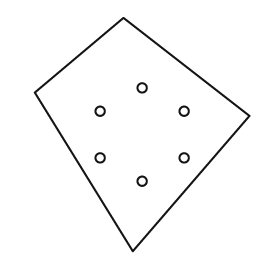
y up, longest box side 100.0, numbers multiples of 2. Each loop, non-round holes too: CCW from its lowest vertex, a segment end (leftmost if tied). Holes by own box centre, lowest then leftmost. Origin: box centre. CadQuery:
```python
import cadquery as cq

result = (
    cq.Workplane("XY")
    .moveTo(-4.0, -50.0)
    .lineTo(46.0, 8.0)
    .lineTo(-8.0, 50.0)
    .lineTo(-46.0, 18.0)
    .close()
    .moveTo(0.0, -20.0)
    .circle(2.0)
    .moveTo(-18.0, -10.0)
    .circle(2.0)
    .moveTo(18.0, -10.0)
    .circle(2.0)
    .moveTo(-18.0, 10.0)
    .circle(2.0)
    .moveTo(18.0, 10.0)
    .circle(2.0)
    .moveTo(0.0, 20.0)
    .circle(2.0)
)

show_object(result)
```